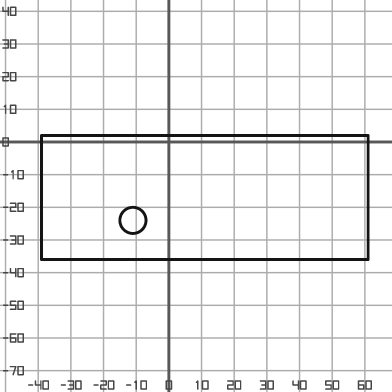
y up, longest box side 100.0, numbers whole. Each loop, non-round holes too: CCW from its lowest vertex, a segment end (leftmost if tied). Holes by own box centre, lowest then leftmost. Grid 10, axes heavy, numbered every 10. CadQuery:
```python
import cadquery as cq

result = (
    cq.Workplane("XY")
    .moveTo(-39.0, -36.0)
    .lineTo(61.0, -36.0)
    .lineTo(61.0, 2.0)
    .lineTo(-39.0, 2.0)
    .close()
    .moveTo(-11.0, -24.0)
    .circle(4.0)
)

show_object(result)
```